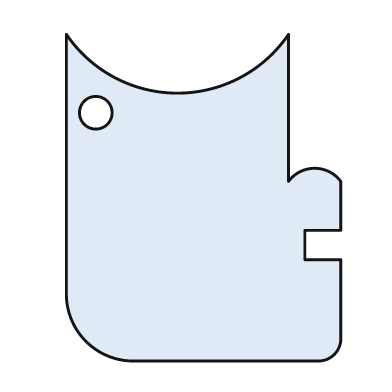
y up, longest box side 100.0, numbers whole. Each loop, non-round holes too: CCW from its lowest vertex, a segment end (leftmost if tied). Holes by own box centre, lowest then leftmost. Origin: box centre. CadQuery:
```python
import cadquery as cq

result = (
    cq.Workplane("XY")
    .moveTo(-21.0, -50.0)
    .lineTo(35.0, -50.0)
    .threePointArc((40.0, -48.0), (42.0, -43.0))
    .lineTo(42.0, -19.0)
    .lineTo(31.0, -19.0)
    .lineTo(31.0, -10.0)
    .lineTo(42.0, -10.0)
    .lineTo(42.0, 5.0)
    .threePointArc((34.0, 9.0), (26.0, 5.0))
    .lineTo(26.0, 50.0)
    .threePointArc((-8.0, 32.0), (-42.0, 50.0))
    .lineTo(-42.0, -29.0)
    .threePointArc((-36.0, -44.0), (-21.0, -50.0))
    .close()
    .moveTo(-33.0, 26.0)
    .circle(5.0)
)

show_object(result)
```